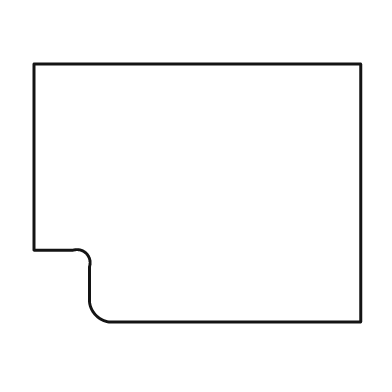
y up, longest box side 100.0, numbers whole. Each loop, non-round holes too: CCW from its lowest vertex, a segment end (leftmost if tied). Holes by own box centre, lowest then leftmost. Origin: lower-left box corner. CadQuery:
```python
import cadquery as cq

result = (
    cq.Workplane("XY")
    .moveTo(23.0, 0.0)
    .lineTo(100.0, 0.0)
    .lineTo(100.0, 79.0)
    .lineTo(0.0, 79.0)
    .lineTo(0.0, 22.0)
    .lineTo(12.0, 22.0)
    .threePointArc((16.0, 21.0), (17.0, 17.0))
    .lineTo(17.0, 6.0)
    .threePointArc((19.0, 2.0), (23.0, 0.0))
    .close()
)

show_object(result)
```